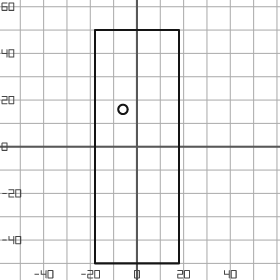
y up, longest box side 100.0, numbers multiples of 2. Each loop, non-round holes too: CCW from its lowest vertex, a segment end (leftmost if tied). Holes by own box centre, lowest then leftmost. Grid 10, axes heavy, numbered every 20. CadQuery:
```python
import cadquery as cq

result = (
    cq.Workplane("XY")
    .moveTo(-18.0, -50.0)
    .lineTo(18.0, -50.0)
    .lineTo(18.0, 50.0)
    .lineTo(-18.0, 50.0)
    .close()
    .moveTo(-6.0, 16.0)
    .circle(2.0)
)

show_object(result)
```